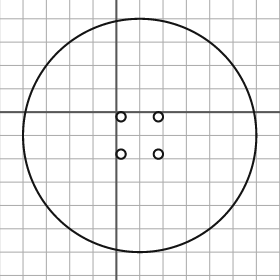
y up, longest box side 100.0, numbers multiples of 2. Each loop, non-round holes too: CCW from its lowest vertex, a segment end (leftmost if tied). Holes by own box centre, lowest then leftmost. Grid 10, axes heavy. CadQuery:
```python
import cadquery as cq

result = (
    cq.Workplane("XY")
    .moveTo(10.0, -10.0)
    .circle(50.0)
    .moveTo(2.0, -18.0)
    .circle(2.0)
    .moveTo(18.0, -18.0)
    .circle(2.0)
    .moveTo(2.0, -2.0)
    .circle(2.0)
    .moveTo(18.0, -2.0)
    .circle(2.0)
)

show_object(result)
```